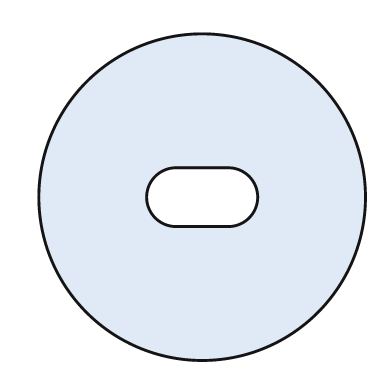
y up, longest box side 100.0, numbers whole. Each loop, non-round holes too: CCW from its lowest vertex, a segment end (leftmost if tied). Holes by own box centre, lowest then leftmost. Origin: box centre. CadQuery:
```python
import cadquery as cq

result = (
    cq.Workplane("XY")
    .moveTo(0.0, 0.0)
    .circle(50.0)
    .moveTo(-8.0, -9.0)
    .lineTo(8.0, -9.0)
    .threePointArc((17.0, 0.0), (8.0, 9.0))
    .lineTo(-8.0, 9.0)
    .threePointArc((-17.0, 0.0), (-8.0, -9.0))
    .close()
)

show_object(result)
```